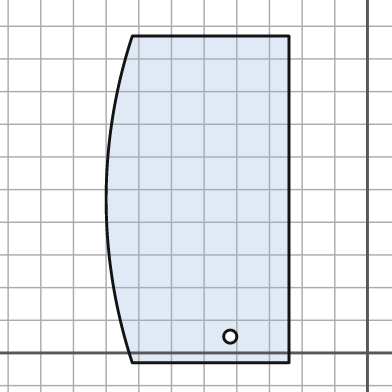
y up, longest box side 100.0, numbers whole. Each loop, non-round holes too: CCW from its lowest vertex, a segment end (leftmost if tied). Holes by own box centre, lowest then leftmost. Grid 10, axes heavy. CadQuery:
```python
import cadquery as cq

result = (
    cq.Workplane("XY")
    .moveTo(-72.0, -3.0)
    .lineTo(-24.0, -3.0)
    .lineTo(-24.0, 97.0)
    .lineTo(-72.0, 97.0)
    .threePointArc((-80.0, 47.0), (-72.0, -3.0))
    .close()
    .moveTo(-42.0, 5.0)
    .circle(2.0)
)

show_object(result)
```